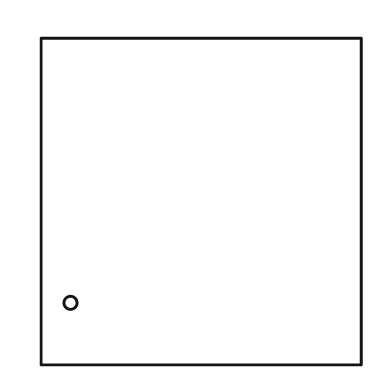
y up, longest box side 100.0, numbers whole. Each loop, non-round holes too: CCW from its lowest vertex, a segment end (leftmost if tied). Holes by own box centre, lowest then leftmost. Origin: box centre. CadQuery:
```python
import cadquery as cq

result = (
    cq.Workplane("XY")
    .moveTo(-49.0, -50.0)
    .lineTo(49.0, -50.0)
    .lineTo(49.0, 50.0)
    .lineTo(-49.0, 50.0)
    .close()
    .moveTo(-40.0, -31.0)
    .circle(2.0)
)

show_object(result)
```